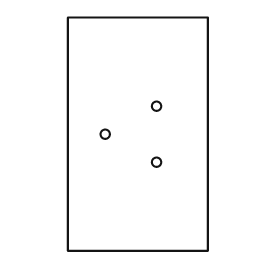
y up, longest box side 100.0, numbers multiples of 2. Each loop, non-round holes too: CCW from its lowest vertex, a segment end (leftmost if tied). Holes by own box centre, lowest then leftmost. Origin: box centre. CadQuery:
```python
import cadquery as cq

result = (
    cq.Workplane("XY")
    .moveTo(-30.0, -50.0)
    .lineTo(30.0, -50.0)
    .lineTo(30.0, 50.0)
    .lineTo(-30.0, 50.0)
    .close()
    .moveTo(8.0, -12.0)
    .circle(2.0)
    .moveTo(-14.0, 0.0)
    .circle(2.0)
    .moveTo(8.0, 12.0)
    .circle(2.0)
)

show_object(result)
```